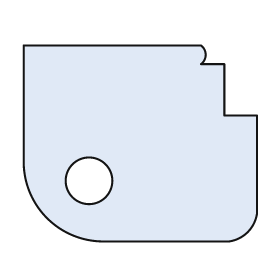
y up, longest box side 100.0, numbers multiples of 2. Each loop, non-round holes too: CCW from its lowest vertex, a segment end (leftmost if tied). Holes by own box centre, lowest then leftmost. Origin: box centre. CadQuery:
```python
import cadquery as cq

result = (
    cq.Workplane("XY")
    .moveTo(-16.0, -42.0)
    .lineTo(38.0, -42.0)
    .threePointArc((46.0, -38.0), (50.0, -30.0))
    .lineTo(50.0, 12.0)
    .lineTo(36.0, 12.0)
    .lineTo(36.0, 34.0)
    .lineTo(26.0, 34.0)
    .threePointArc((28.0, 38.0), (26.0, 42.0))
    .lineTo(-50.0, 42.0)
    .lineTo(-50.0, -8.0)
    .threePointArc((-40.0, -32.0), (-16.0, -42.0))
    .close()
    .moveTo(-22.0, -16.0)
    .circle(10.0)
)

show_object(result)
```